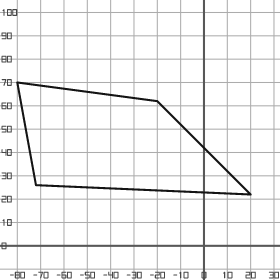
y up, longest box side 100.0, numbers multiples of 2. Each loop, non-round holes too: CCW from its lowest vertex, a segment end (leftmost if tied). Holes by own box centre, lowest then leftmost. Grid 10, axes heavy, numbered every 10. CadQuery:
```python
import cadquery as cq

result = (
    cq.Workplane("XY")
    .moveTo(20.0, 22.0)
    .lineTo(-20.0, 62.0)
    .lineTo(-80.0, 70.0)
    .lineTo(-72.0, 26.0)
    .close()
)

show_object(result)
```